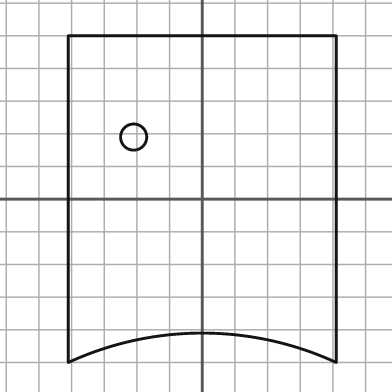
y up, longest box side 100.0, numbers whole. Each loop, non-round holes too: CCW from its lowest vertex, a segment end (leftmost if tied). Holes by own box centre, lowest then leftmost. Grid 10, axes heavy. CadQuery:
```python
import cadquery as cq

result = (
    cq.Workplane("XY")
    .moveTo(-41.0, -50.0)
    .threePointArc((0.0, -41.0), (41.0, -50.0))
    .lineTo(41.0, 50.0)
    .lineTo(-41.0, 50.0)
    .close()
    .moveTo(-21.0, 19.0)
    .circle(4.0)
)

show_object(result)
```